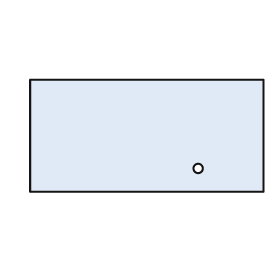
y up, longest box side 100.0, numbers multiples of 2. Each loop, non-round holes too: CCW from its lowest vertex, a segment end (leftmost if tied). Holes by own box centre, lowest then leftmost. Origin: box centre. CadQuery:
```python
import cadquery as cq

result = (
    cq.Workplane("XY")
    .moveTo(-50.0, -24.0)
    .lineTo(50.0, -24.0)
    .lineTo(50.0, 24.0)
    .lineTo(-50.0, 24.0)
    .close()
    .moveTo(22.0, -14.0)
    .circle(2.0)
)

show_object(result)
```